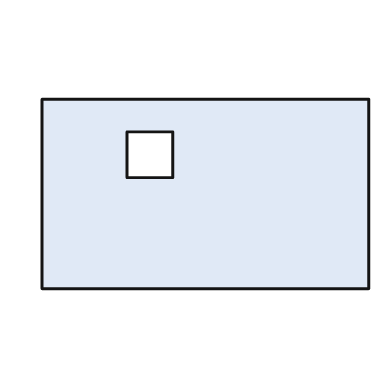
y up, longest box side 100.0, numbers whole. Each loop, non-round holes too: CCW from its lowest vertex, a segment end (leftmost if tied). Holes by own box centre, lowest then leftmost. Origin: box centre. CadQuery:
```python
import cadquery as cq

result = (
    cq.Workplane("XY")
    .moveTo(-50.0, -29.0)
    .lineTo(50.0, -29.0)
    .lineTo(50.0, 29.0)
    .lineTo(-50.0, 29.0)
    .close()
    .moveTo(-24.0, 5.0)
    .lineTo(-10.0, 5.0)
    .lineTo(-10.0, 19.0)
    .lineTo(-24.0, 19.0)
    .close()
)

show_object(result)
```